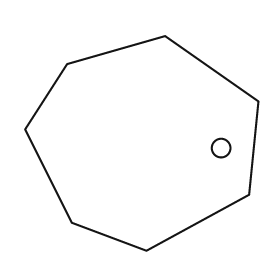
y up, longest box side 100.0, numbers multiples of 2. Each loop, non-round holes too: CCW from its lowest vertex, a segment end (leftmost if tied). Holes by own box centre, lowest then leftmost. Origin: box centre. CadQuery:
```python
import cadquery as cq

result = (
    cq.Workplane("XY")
    .moveTo(2.0, -46.0)
    .lineTo(46.0, -22.0)
    .lineTo(50.0, 18.0)
    .lineTo(10.0, 46.0)
    .lineTo(-32.0, 34.0)
    .lineTo(-50.0, 6.0)
    .lineTo(-30.0, -34.0)
    .close()
    .moveTo(34.0, -2.0)
    .circle(4.0)
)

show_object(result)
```